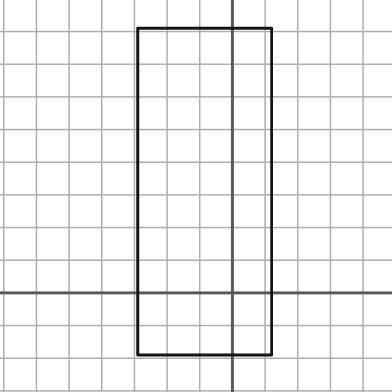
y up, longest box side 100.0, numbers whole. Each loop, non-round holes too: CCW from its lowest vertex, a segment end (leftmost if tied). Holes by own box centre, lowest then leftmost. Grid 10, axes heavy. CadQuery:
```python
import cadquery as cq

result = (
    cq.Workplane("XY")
    .moveTo(-29.0, -19.0)
    .lineTo(12.0, -19.0)
    .lineTo(12.0, 81.0)
    .lineTo(-29.0, 81.0)
    .close()
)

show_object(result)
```